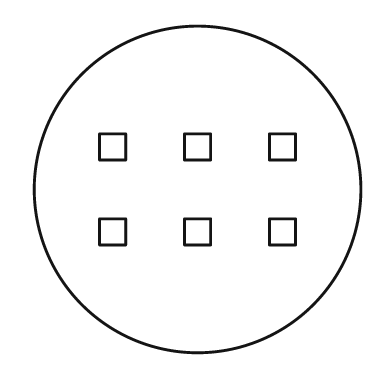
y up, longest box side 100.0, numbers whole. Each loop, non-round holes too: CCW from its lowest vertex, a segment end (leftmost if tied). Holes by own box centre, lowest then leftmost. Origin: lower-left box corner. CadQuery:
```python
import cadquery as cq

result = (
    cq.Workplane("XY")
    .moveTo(50.0, 50.0)
    .circle(50.0)
    .moveTo(20.0, 33.0)
    .lineTo(28.0, 33.0)
    .lineTo(28.0, 41.0)
    .lineTo(20.0, 41.0)
    .close()
    .moveTo(46.0, 33.0)
    .lineTo(54.0, 33.0)
    .lineTo(54.0, 41.0)
    .lineTo(46.0, 41.0)
    .close()
    .moveTo(72.0, 33.0)
    .lineTo(80.0, 33.0)
    .lineTo(80.0, 41.0)
    .lineTo(72.0, 41.0)
    .close()
    .moveTo(20.0, 59.0)
    .lineTo(28.0, 59.0)
    .lineTo(28.0, 67.0)
    .lineTo(20.0, 67.0)
    .close()
    .moveTo(46.0, 59.0)
    .lineTo(54.0, 59.0)
    .lineTo(54.0, 67.0)
    .lineTo(46.0, 67.0)
    .close()
    .moveTo(72.0, 59.0)
    .lineTo(80.0, 59.0)
    .lineTo(80.0, 67.0)
    .lineTo(72.0, 67.0)
    .close()
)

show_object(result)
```